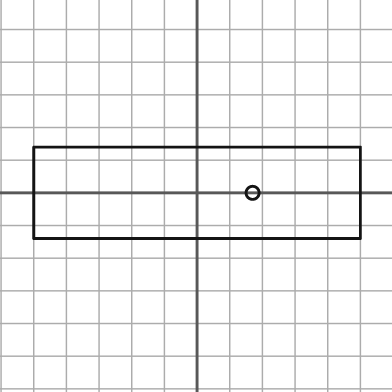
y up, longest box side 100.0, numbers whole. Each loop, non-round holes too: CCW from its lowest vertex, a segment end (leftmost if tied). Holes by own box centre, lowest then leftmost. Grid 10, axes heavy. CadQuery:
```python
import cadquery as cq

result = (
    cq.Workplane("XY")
    .moveTo(-50.0, -14.0)
    .lineTo(50.0, -14.0)
    .lineTo(50.0, 14.0)
    .lineTo(-50.0, 14.0)
    .close()
    .moveTo(17.0, 0.0)
    .circle(2.0)
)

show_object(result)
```